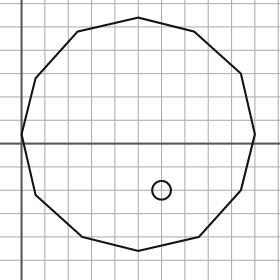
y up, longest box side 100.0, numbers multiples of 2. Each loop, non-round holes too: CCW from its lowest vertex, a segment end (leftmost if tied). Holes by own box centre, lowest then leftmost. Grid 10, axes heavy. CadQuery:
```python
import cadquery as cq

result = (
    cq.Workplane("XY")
    .moveTo(50.0, -46.0)
    .lineTo(76.0, -40.0)
    .lineTo(94.0, -20.0)
    .lineTo(100.0, 4.0)
    .lineTo(94.0, 30.0)
    .lineTo(74.0, 48.0)
    .lineTo(50.0, 54.0)
    .lineTo(24.0, 48.0)
    .lineTo(6.0, 28.0)
    .lineTo(0.0, 4.0)
    .lineTo(6.0, -22.0)
    .lineTo(26.0, -40.0)
    .close()
    .moveTo(60.0, -20.0)
    .circle(4.0)
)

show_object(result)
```